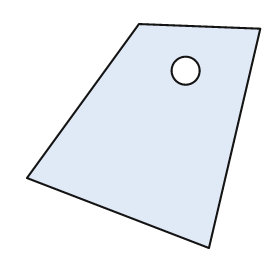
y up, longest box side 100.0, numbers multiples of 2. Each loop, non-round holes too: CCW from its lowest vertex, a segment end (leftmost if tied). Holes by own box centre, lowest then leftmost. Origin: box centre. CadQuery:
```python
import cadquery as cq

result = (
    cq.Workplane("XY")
    .moveTo(28.0, -48.0)
    .lineTo(50.0, 46.0)
    .lineTo(-2.0, 48.0)
    .lineTo(-50.0, -18.0)
    .close()
    .moveTo(18.0, 28.0)
    .circle(6.0)
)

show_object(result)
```